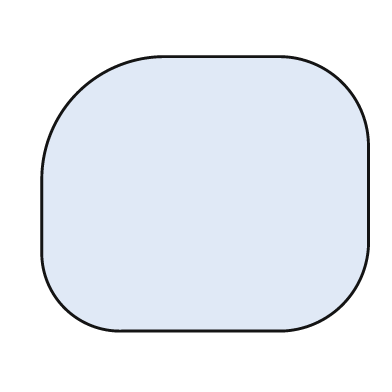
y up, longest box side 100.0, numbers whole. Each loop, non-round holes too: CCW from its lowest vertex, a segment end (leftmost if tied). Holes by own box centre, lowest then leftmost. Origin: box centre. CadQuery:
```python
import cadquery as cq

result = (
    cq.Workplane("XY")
    .moveTo(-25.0, -42.0)
    .lineTo(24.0, -42.0)
    .threePointArc((42.0, -34.0), (50.0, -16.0))
    .lineTo(50.0, 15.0)
    .threePointArc((42.0, 34.0), (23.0, 42.0))
    .lineTo(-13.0, 42.0)
    .threePointArc((-39.0, 31.0), (-50.0, 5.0))
    .lineTo(-50.0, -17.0)
    .threePointArc((-43.0, -35.0), (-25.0, -42.0))
    .close()
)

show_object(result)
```